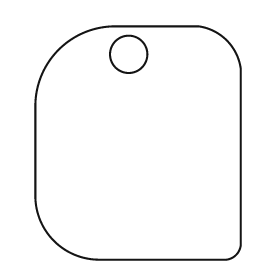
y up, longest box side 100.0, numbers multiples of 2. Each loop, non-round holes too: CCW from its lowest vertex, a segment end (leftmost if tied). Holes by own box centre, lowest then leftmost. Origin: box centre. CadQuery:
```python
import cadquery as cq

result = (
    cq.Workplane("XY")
    .moveTo(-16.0, -50.0)
    .lineTo(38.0, -50.0)
    .threePointArc((42.0, -48.0), (44.0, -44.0))
    .lineTo(44.0, 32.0)
    .threePointArc((38.0, 44.0), (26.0, 50.0))
    .lineTo(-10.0, 50.0)
    .threePointArc((-34.0, 40.0), (-44.0, 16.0))
    .lineTo(-44.0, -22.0)
    .threePointArc((-36.0, -42.0), (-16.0, -50.0))
    .close()
    .moveTo(-4.0, 38.0)
    .circle(8.0)
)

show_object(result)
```